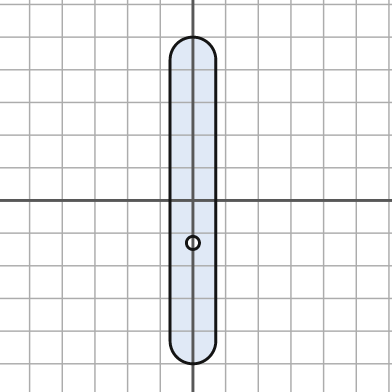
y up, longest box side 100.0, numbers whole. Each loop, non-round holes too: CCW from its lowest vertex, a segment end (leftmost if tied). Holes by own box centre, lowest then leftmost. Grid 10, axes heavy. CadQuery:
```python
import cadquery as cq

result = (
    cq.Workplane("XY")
    .moveTo(-7.0, -43.0)
    .threePointArc((0.0, -50.0), (7.0, -43.0))
    .lineTo(7.0, 43.0)
    .threePointArc((0.0, 50.0), (-7.0, 43.0))
    .close()
    .moveTo(0.0, -13.0)
    .circle(2.0)
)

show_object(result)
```